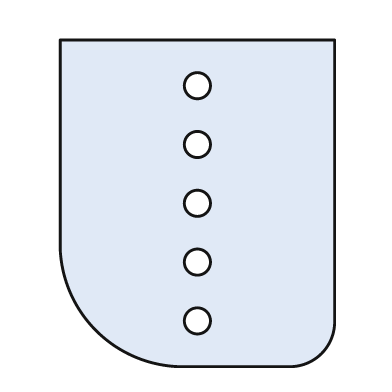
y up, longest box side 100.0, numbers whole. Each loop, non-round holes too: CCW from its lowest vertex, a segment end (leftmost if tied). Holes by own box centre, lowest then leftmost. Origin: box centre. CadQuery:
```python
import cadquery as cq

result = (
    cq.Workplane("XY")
    .moveTo(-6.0, -50.0)
    .lineTo(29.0, -50.0)
    .threePointArc((38.0, -46.0), (42.0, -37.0))
    .lineTo(42.0, 50.0)
    .lineTo(-42.0, 50.0)
    .lineTo(-42.0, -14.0)
    .threePointArc((-31.0, -39.0), (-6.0, -50.0))
    .close()
    .moveTo(0.0, -36.0)
    .circle(4.0)
    .moveTo(0.0, -18.0)
    .circle(4.0)
    .moveTo(0.0, 0.0)
    .circle(4.0)
    .moveTo(0.0, 18.0)
    .circle(4.0)
    .moveTo(0.0, 36.0)
    .circle(4.0)
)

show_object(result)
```